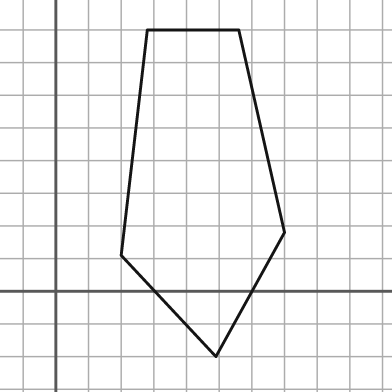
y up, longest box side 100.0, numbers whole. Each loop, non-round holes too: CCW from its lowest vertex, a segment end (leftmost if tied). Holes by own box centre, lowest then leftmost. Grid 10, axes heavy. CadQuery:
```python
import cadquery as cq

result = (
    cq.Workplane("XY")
    .moveTo(49.0, -20.0)
    .lineTo(70.0, 18.0)
    .lineTo(56.0, 80.0)
    .lineTo(28.0, 80.0)
    .lineTo(20.0, 11.0)
    .close()
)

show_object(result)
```